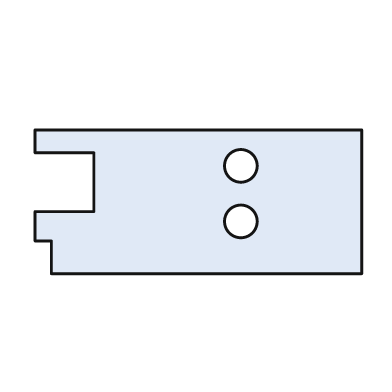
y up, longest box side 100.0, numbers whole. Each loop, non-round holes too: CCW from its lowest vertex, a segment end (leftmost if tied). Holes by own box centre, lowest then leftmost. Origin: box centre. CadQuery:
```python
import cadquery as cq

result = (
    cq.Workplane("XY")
    .moveTo(-45.0, -22.0)
    .lineTo(50.0, -22.0)
    .lineTo(50.0, 22.0)
    .lineTo(-50.0, 22.0)
    .lineTo(-50.0, 15.0)
    .lineTo(-32.0, 15.0)
    .lineTo(-32.0, -3.0)
    .lineTo(-50.0, -3.0)
    .lineTo(-50.0, -12.0)
    .lineTo(-45.0, -12.0)
    .close()
    .moveTo(13.0, -6.0)
    .circle(5.0)
    .moveTo(13.0, 11.0)
    .circle(5.0)
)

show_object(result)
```